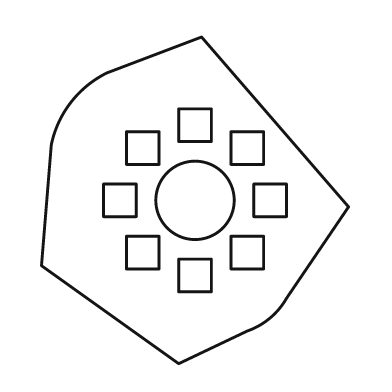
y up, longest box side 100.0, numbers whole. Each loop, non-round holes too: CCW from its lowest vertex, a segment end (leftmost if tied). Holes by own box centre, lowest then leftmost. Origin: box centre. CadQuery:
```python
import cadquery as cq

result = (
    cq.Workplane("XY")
    .moveTo(-5.0, -50.0)
    .lineTo(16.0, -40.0)
    .threePointArc((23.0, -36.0), (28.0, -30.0))
    .lineTo(47.0, -2.0)
    .lineTo(2.0, 50.0)
    .lineTo(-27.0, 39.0)
    .threePointArc((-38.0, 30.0), (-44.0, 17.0))
    .lineTo(-47.0, -20.0)
    .close()
    .moveTo(-5.0, -28.0)
    .lineTo(5.0, -28.0)
    .lineTo(5.0, -18.0)
    .lineTo(-5.0, -18.0)
    .close()
    .moveTo(-21.0, -21.0)
    .lineTo(-11.0, -21.0)
    .lineTo(-11.0, -11.0)
    .lineTo(-21.0, -11.0)
    .close()
    .moveTo(11.0, -21.0)
    .lineTo(21.0, -21.0)
    .lineTo(21.0, -11.0)
    .lineTo(11.0, -11.0)
    .close()
    .moveTo(-28.0, -5.0)
    .lineTo(-18.0, -5.0)
    .lineTo(-18.0, 5.0)
    .lineTo(-28.0, 5.0)
    .close()
    .moveTo(0.0, 0.0)
    .circle(12.0)
    .moveTo(18.0, -5.0)
    .lineTo(28.0, -5.0)
    .lineTo(28.0, 5.0)
    .lineTo(18.0, 5.0)
    .close()
    .moveTo(-21.0, 11.0)
    .lineTo(-11.0, 11.0)
    .lineTo(-11.0, 21.0)
    .lineTo(-21.0, 21.0)
    .close()
    .moveTo(11.0, 11.0)
    .lineTo(21.0, 11.0)
    .lineTo(21.0, 21.0)
    .lineTo(11.0, 21.0)
    .close()
    .moveTo(-5.0, 18.0)
    .lineTo(5.0, 18.0)
    .lineTo(5.0, 28.0)
    .lineTo(-5.0, 28.0)
    .close()
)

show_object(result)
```